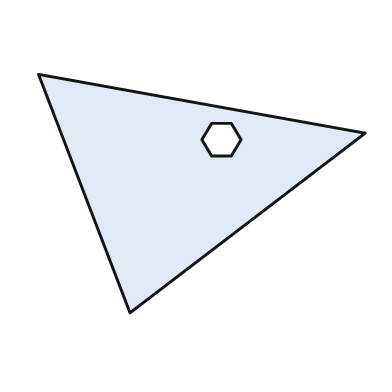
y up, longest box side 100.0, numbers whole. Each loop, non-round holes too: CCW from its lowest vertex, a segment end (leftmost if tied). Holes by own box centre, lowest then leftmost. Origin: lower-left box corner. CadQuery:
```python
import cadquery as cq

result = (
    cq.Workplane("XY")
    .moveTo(28.0, 0.0)
    .lineTo(100.0, 55.0)
    .lineTo(0.0, 73.0)
    .close()
    .moveTo(53.0, 48.0)
    .lineTo(59.0, 48.0)
    .lineTo(62.0, 53.0)
    .lineTo(59.0, 58.0)
    .lineTo(53.0, 58.0)
    .lineTo(50.0, 53.0)
    .close()
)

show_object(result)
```